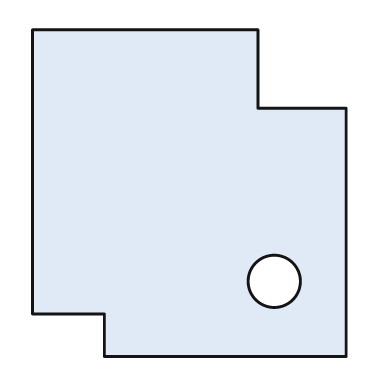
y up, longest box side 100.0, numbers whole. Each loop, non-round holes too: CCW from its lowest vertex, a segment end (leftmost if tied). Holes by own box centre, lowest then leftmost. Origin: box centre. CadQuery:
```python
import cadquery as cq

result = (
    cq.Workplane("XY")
    .moveTo(-26.0, -50.0)
    .lineTo(48.0, -50.0)
    .lineTo(48.0, 26.0)
    .lineTo(21.0, 26.0)
    .lineTo(21.0, 50.0)
    .lineTo(-48.0, 50.0)
    .lineTo(-48.0, -37.0)
    .lineTo(-26.0, -37.0)
    .close()
    .moveTo(26.0, -27.0)
    .circle(8.0)
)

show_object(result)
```